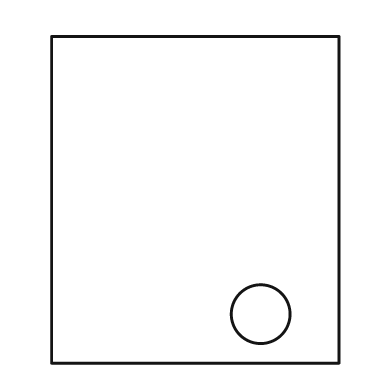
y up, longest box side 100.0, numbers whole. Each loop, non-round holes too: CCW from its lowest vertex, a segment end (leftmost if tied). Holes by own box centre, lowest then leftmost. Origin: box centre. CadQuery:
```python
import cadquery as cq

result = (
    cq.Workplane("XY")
    .moveTo(-44.0, -50.0)
    .lineTo(44.0, -50.0)
    .lineTo(44.0, 50.0)
    .lineTo(-44.0, 50.0)
    .close()
    .moveTo(20.0, -35.0)
    .circle(9.0)
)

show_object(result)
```